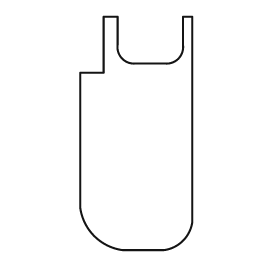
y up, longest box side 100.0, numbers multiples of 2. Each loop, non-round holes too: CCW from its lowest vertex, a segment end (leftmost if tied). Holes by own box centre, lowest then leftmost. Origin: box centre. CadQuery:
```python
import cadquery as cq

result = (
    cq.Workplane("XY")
    .moveTo(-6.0, -50.0)
    .lineTo(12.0, -50.0)
    .threePointArc((20.0, -46.0), (24.0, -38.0))
    .lineTo(24.0, 50.0)
    .lineTo(20.0, 50.0)
    .lineTo(20.0, 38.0)
    .threePointArc((18.0, 32.0), (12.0, 30.0))
    .lineTo(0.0, 30.0)
    .threePointArc((-6.0, 32.0), (-8.0, 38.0))
    .lineTo(-8.0, 50.0)
    .lineTo(-14.0, 50.0)
    .lineTo(-14.0, 26.0)
    .lineTo(-24.0, 26.0)
    .lineTo(-24.0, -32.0)
    .threePointArc((-18.0, -44.0), (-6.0, -50.0))
    .close()
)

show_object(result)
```